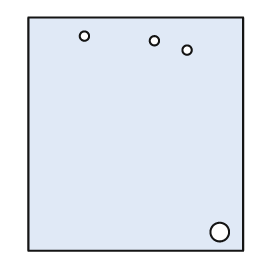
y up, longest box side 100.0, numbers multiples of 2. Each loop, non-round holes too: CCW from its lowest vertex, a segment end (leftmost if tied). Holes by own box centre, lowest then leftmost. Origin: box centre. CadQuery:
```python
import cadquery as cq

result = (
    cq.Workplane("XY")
    .moveTo(-46.0, -50.0)
    .lineTo(46.0, -50.0)
    .lineTo(46.0, 50.0)
    .lineTo(-46.0, 50.0)
    .close()
    .moveTo(36.0, -42.0)
    .circle(4.0)
    .moveTo(22.0, 36.0)
    .circle(2.0)
    .moveTo(8.0, 40.0)
    .circle(2.0)
    .moveTo(-22.0, 42.0)
    .circle(2.0)
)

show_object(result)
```